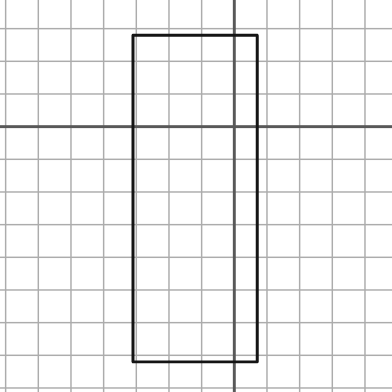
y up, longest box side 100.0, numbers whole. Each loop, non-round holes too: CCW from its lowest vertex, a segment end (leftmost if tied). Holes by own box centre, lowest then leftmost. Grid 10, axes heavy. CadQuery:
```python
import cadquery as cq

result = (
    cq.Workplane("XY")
    .moveTo(-31.0, -72.0)
    .lineTo(7.0, -72.0)
    .lineTo(7.0, 28.0)
    .lineTo(-31.0, 28.0)
    .close()
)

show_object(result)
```